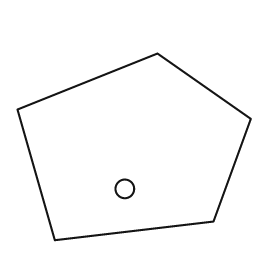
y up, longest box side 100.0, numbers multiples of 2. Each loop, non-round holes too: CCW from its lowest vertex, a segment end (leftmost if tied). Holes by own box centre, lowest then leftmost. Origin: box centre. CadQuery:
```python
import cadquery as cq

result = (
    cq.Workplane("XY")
    .moveTo(-34.0, -40.0)
    .lineTo(34.0, -32.0)
    .lineTo(50.0, 12.0)
    .lineTo(10.0, 40.0)
    .lineTo(-50.0, 16.0)
    .close()
    .moveTo(-4.0, -18.0)
    .circle(4.0)
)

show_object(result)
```